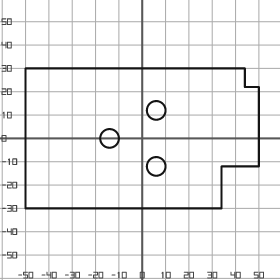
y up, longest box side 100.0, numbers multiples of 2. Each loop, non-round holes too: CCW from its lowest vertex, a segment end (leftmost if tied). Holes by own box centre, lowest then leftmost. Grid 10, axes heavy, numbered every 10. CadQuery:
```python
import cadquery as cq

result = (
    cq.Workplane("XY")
    .moveTo(-50.0, -30.0)
    .lineTo(34.0, -30.0)
    .lineTo(34.0, -12.0)
    .lineTo(50.0, -12.0)
    .lineTo(50.0, 22.0)
    .lineTo(44.0, 22.0)
    .lineTo(44.0, 30.0)
    .lineTo(-50.0, 30.0)
    .close()
    .moveTo(6.0, -12.0)
    .circle(4.0)
    .moveTo(-14.0, 0.0)
    .circle(4.0)
    .moveTo(6.0, 12.0)
    .circle(4.0)
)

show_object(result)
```